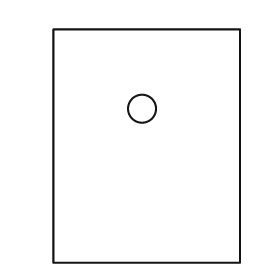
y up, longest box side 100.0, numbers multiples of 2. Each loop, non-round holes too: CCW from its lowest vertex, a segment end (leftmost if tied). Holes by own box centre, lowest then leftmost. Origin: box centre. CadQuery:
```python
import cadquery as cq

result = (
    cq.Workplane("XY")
    .moveTo(-40.0, -50.0)
    .lineTo(40.0, -50.0)
    .lineTo(40.0, 50.0)
    .lineTo(-40.0, 50.0)
    .close()
    .moveTo(-2.0, 16.0)
    .circle(6.0)
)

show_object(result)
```